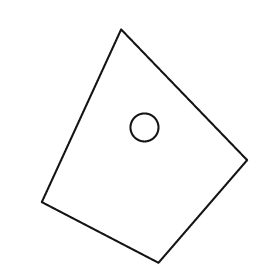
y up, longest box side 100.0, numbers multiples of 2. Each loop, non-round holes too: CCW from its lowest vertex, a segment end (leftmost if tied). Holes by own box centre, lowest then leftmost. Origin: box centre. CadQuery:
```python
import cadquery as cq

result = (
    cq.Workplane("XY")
    .moveTo(6.0, -50.0)
    .lineTo(44.0, -6.0)
    .lineTo(-10.0, 50.0)
    .lineTo(-44.0, -24.0)
    .close()
    .moveTo(0.0, 8.0)
    .circle(6.0)
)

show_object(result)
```